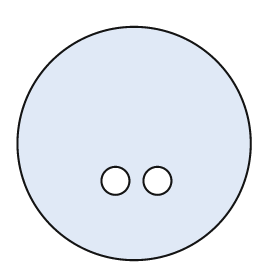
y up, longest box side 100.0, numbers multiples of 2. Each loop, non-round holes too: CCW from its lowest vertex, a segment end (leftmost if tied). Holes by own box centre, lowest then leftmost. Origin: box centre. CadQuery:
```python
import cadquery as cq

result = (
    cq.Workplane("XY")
    .moveTo(0.0, 0.0)
    .circle(50.0)
    .moveTo(-8.0, -16.0)
    .circle(6.0)
    .moveTo(10.0, -16.0)
    .circle(6.0)
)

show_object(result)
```